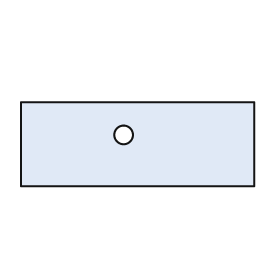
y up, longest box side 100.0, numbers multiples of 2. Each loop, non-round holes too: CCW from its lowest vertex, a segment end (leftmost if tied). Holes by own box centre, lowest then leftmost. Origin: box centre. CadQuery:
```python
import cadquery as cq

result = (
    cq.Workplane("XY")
    .moveTo(-50.0, -18.0)
    .lineTo(50.0, -18.0)
    .lineTo(50.0, 18.0)
    .lineTo(-50.0, 18.0)
    .close()
    .moveTo(-6.0, 4.0)
    .circle(4.0)
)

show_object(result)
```